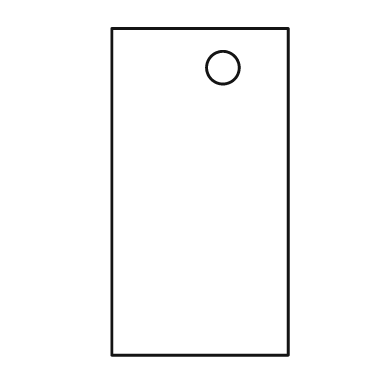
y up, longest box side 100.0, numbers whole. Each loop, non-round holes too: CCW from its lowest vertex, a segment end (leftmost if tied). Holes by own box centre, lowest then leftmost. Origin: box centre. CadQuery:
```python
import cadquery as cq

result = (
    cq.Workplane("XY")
    .moveTo(-27.0, -50.0)
    .lineTo(27.0, -50.0)
    .lineTo(27.0, 50.0)
    .lineTo(-27.0, 50.0)
    .close()
    .moveTo(7.0, 38.0)
    .circle(5.0)
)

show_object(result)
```